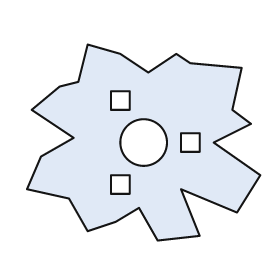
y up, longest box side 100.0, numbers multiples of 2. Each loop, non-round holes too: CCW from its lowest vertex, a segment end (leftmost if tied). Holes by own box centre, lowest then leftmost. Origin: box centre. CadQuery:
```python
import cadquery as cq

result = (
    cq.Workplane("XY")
    .moveTo(6.0, -42.0)
    .lineTo(24.0, -40.0)
    .lineTo(16.0, -20.0)
    .lineTo(40.0, -30.0)
    .lineTo(50.0, -14.0)
    .lineTo(30.0, 0.0)
    .lineTo(46.0, 8.0)
    .lineTo(38.0, 14.0)
    .lineTo(42.0, 32.0)
    .lineTo(20.0, 34.0)
    .lineTo(14.0, 38.0)
    .lineTo(2.0, 30.0)
    .lineTo(-10.0, 38.0)
    .lineTo(-24.0, 42.0)
    .lineTo(-28.0, 26.0)
    .lineTo(-36.0, 24.0)
    .lineTo(-48.0, 14.0)
    .lineTo(-30.0, 2.0)
    .lineTo(-44.0, -6.0)
    .lineTo(-50.0, -20.0)
    .lineTo(-32.0, -24.0)
    .lineTo(-24.0, -38.0)
    .lineTo(-12.0, -34.0)
    .lineTo(-2.0, -28.0)
    .close()
    .moveTo(-14.0, -22.0)
    .lineTo(-6.0, -22.0)
    .lineTo(-6.0, -14.0)
    .lineTo(-14.0, -14.0)
    .close()
    .moveTo(0.0, 0.0)
    .circle(10.0)
    .moveTo(16.0, -4.0)
    .lineTo(24.0, -4.0)
    .lineTo(24.0, 4.0)
    .lineTo(16.0, 4.0)
    .close()
    .moveTo(-14.0, 14.0)
    .lineTo(-6.0, 14.0)
    .lineTo(-6.0, 22.0)
    .lineTo(-14.0, 22.0)
    .close()
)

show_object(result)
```